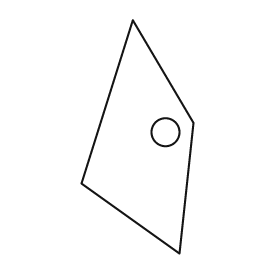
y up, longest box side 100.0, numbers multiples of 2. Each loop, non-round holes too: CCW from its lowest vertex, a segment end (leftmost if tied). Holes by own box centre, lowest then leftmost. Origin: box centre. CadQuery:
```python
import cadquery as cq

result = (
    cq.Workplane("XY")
    .moveTo(18.0, -50.0)
    .lineTo(24.0, 6.0)
    .lineTo(-2.0, 50.0)
    .lineTo(-24.0, -20.0)
    .close()
    .moveTo(12.0, 2.0)
    .circle(6.0)
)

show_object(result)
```